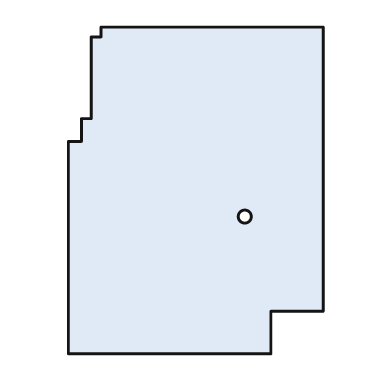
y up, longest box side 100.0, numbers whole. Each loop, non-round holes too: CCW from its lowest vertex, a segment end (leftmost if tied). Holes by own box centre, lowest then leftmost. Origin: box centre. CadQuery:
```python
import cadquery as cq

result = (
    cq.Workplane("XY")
    .moveTo(-39.0, -50.0)
    .lineTo(23.0, -50.0)
    .lineTo(23.0, -37.0)
    .lineTo(39.0, -37.0)
    .lineTo(39.0, 50.0)
    .lineTo(-29.0, 50.0)
    .lineTo(-29.0, 47.0)
    .lineTo(-32.0, 47.0)
    .lineTo(-32.0, 22.0)
    .lineTo(-35.0, 22.0)
    .lineTo(-35.0, 15.0)
    .lineTo(-39.0, 15.0)
    .close()
    .moveTo(15.0, -8.0)
    .circle(2.0)
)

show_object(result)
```